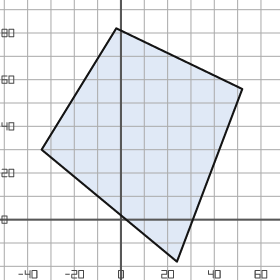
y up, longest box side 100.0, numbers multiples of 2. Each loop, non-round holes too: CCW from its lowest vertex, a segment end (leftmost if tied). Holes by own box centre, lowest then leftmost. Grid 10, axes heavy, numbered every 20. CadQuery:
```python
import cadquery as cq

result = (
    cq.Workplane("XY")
    .moveTo(24.0, -18.0)
    .lineTo(52.0, 56.0)
    .lineTo(-2.0, 82.0)
    .lineTo(-34.0, 30.0)
    .close()
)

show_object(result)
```